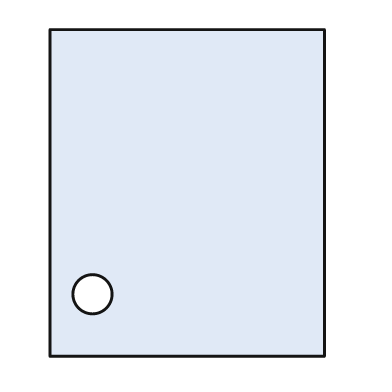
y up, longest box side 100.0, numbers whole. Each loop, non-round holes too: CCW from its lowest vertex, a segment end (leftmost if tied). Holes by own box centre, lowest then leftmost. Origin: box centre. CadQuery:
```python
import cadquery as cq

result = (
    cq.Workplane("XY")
    .moveTo(-42.0, -50.0)
    .lineTo(42.0, -50.0)
    .lineTo(42.0, 50.0)
    .lineTo(-42.0, 50.0)
    .close()
    .moveTo(-29.0, -31.0)
    .circle(6.0)
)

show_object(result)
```